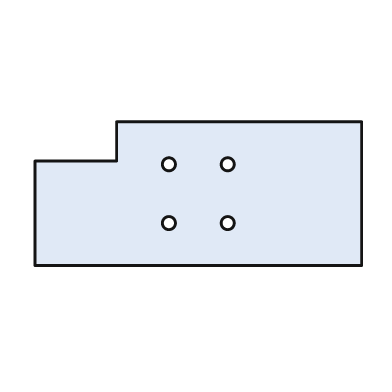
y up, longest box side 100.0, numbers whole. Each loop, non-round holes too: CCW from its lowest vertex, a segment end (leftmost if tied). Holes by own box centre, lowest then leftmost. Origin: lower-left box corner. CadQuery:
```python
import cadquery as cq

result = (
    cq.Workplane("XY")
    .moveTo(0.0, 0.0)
    .lineTo(100.0, 0.0)
    .lineTo(100.0, 44.0)
    .lineTo(25.0, 44.0)
    .lineTo(25.0, 32.0)
    .lineTo(0.0, 32.0)
    .close()
    .moveTo(41.0, 13.0)
    .circle(2.0)
    .moveTo(59.0, 13.0)
    .circle(2.0)
    .moveTo(41.0, 31.0)
    .circle(2.0)
    .moveTo(59.0, 31.0)
    .circle(2.0)
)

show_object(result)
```